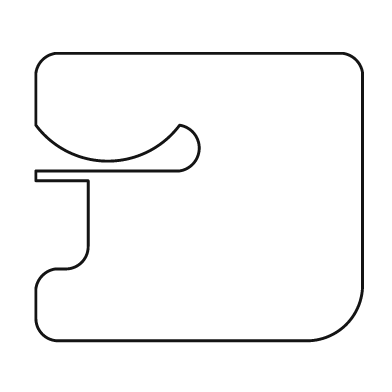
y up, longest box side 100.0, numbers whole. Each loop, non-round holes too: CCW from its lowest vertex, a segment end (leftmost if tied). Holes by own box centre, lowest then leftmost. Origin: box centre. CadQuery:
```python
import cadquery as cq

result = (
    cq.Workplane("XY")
    .moveTo(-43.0, -44.0)
    .lineTo(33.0, -44.0)
    .threePointArc((45.0, -39.0), (50.0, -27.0))
    .lineTo(50.0, 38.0)
    .threePointArc((48.0, 42.0), (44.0, 44.0))
    .lineTo(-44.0, 44.0)
    .threePointArc((-48.0, 42.0), (-50.0, 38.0))
    .lineTo(-50.0, 22.0)
    .threePointArc((-28.0, 11.0), (-6.0, 22.0))
    .threePointArc((0.0, 15.0), (-6.0, 8.0))
    .lineTo(-50.0, 8.0)
    .lineTo(-50.0, 5.0)
    .lineTo(-34.0, 5.0)
    .lineTo(-34.0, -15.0)
    .threePointArc((-36.0, -20.0), (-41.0, -22.0))
    .lineTo(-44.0, -22.0)
    .threePointArc((-48.0, -24.0), (-50.0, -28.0))
    .lineTo(-50.0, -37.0)
    .threePointArc((-48.0, -42.0), (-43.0, -44.0))
    .close()
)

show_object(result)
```